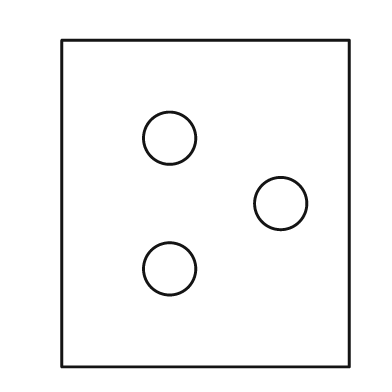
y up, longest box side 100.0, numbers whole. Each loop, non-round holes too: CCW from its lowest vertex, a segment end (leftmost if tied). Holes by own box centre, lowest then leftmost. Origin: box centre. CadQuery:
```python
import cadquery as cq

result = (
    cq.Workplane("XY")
    .moveTo(-44.0, -50.0)
    .lineTo(44.0, -50.0)
    .lineTo(44.0, 50.0)
    .lineTo(-44.0, 50.0)
    .close()
    .moveTo(-11.0, -20.0)
    .circle(8.0)
    .moveTo(23.0, 0.0)
    .circle(8.0)
    .moveTo(-11.0, 20.0)
    .circle(8.0)
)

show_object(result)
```